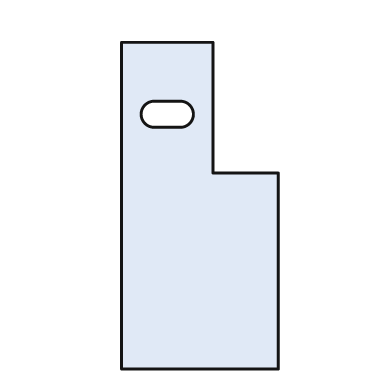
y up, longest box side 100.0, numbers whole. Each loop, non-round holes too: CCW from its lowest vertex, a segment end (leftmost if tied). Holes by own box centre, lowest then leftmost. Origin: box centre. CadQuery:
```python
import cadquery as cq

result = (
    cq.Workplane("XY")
    .moveTo(-24.0, -50.0)
    .lineTo(24.0, -50.0)
    .lineTo(24.0, 10.0)
    .lineTo(4.0, 10.0)
    .lineTo(4.0, 50.0)
    .lineTo(-24.0, 50.0)
    .close()
    .moveTo(-14.0, 24.0)
    .lineTo(-6.0, 24.0)
    .threePointArc((-2.0, 28.0), (-6.0, 32.0))
    .lineTo(-14.0, 32.0)
    .threePointArc((-18.0, 28.0), (-14.0, 24.0))
    .close()
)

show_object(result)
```